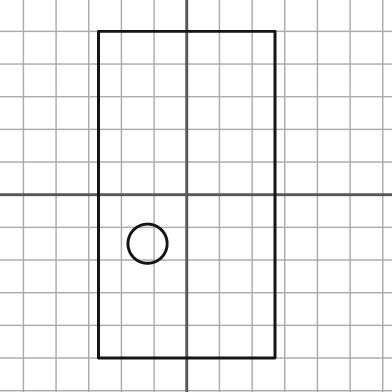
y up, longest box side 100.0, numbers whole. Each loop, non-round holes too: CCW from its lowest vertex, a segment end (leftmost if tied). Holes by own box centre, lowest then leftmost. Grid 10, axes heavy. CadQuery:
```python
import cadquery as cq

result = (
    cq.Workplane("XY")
    .moveTo(-27.0, -50.0)
    .lineTo(27.0, -50.0)
    .lineTo(27.0, 50.0)
    .lineTo(-27.0, 50.0)
    .close()
    .moveTo(-12.0, -15.0)
    .circle(6.0)
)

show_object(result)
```